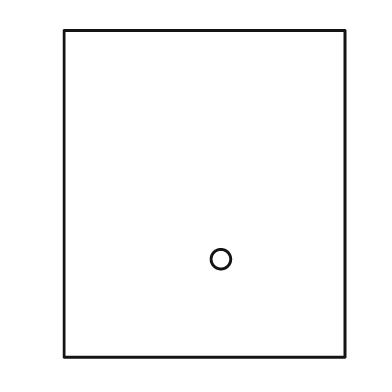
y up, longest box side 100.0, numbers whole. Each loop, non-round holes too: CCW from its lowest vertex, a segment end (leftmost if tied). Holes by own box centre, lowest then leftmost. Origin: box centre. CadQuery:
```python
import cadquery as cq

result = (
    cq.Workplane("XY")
    .moveTo(-43.0, -50.0)
    .lineTo(43.0, -50.0)
    .lineTo(43.0, 50.0)
    .lineTo(-43.0, 50.0)
    .close()
    .moveTo(5.0, -20.0)
    .circle(3.0)
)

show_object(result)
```